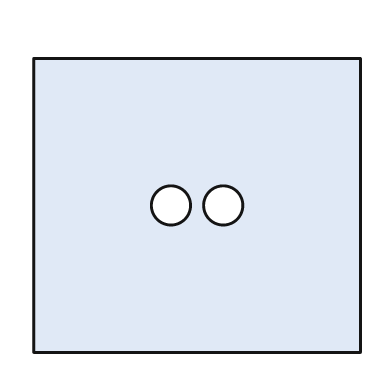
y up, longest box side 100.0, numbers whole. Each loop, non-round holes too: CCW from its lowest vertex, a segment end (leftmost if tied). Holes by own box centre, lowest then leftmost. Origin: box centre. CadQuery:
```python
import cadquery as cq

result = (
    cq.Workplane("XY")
    .moveTo(-50.0, -45.0)
    .lineTo(50.0, -45.0)
    .lineTo(50.0, 45.0)
    .lineTo(-50.0, 45.0)
    .close()
    .moveTo(-8.0, 0.0)
    .circle(6.0)
    .moveTo(8.0, 0.0)
    .circle(6.0)
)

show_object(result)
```